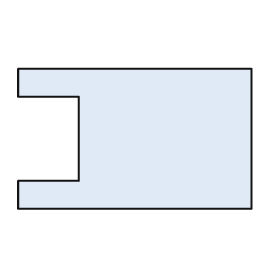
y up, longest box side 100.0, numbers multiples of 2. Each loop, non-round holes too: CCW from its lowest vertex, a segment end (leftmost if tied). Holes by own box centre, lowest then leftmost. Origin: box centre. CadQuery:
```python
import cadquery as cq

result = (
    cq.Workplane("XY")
    .moveTo(-50.0, -30.0)
    .lineTo(50.0, -30.0)
    .lineTo(50.0, 30.0)
    .lineTo(-50.0, 30.0)
    .lineTo(-50.0, 18.0)
    .lineTo(-24.0, 18.0)
    .lineTo(-24.0, -18.0)
    .lineTo(-50.0, -18.0)
    .close()
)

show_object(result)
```